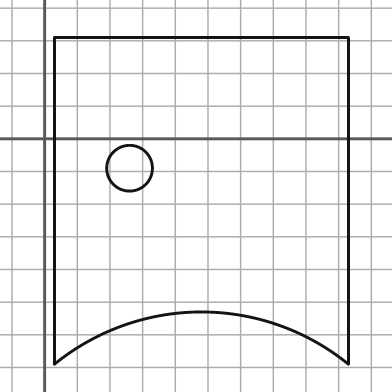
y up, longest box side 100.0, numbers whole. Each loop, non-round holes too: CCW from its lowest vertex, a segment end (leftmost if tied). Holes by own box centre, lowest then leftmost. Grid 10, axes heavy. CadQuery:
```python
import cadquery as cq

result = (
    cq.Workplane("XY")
    .moveTo(3.0, -69.0)
    .threePointArc((48.0, -53.0), (93.0, -69.0))
    .lineTo(93.0, 31.0)
    .lineTo(3.0, 31.0)
    .close()
    .moveTo(26.0, -9.0)
    .circle(7.0)
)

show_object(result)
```